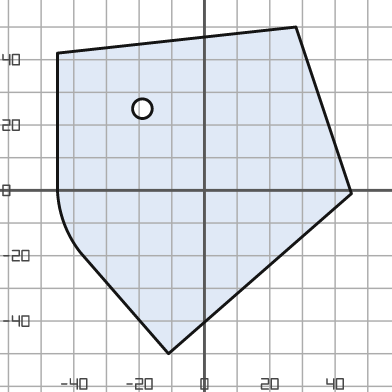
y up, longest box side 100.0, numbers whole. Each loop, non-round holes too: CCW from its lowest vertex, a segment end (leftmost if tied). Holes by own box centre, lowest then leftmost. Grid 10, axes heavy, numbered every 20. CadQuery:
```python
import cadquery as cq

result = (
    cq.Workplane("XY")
    .moveTo(-11.0, -50.0)
    .lineTo(45.0, -1.0)
    .lineTo(28.0, 50.0)
    .lineTo(-45.0, 42.0)
    .lineTo(-45.0, 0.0)
    .threePointArc((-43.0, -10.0), (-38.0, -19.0))
    .close()
    .moveTo(-19.0, 25.0)
    .circle(3.0)
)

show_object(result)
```